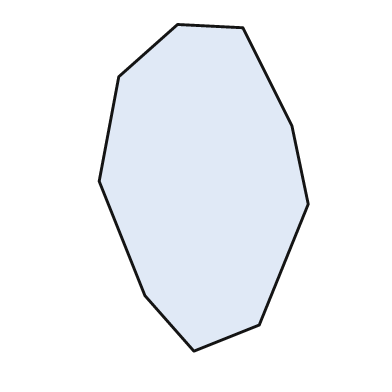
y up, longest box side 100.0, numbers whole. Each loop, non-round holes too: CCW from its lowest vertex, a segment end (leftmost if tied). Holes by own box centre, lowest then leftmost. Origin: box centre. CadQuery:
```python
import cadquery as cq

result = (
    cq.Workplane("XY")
    .moveTo(-3.0, -50.0)
    .lineTo(17.0, -42.0)
    .lineTo(32.0, -5.0)
    .lineTo(27.0, 19.0)
    .lineTo(12.0, 49.0)
    .lineTo(-8.0, 50.0)
    .lineTo(-26.0, 34.0)
    .lineTo(-32.0, 2.0)
    .lineTo(-18.0, -33.0)
    .close()
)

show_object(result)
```